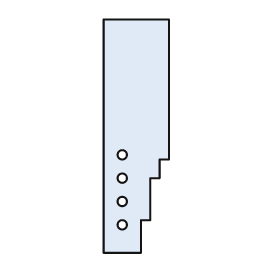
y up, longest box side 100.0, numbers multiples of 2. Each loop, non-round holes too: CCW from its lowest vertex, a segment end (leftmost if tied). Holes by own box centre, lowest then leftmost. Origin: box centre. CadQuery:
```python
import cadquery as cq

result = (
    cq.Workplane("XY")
    .moveTo(-14.0, -50.0)
    .lineTo(2.0, -50.0)
    .lineTo(2.0, -36.0)
    .lineTo(6.0, -36.0)
    .lineTo(6.0, -18.0)
    .lineTo(10.0, -18.0)
    .lineTo(10.0, -10.0)
    .lineTo(14.0, -10.0)
    .lineTo(14.0, 50.0)
    .lineTo(-14.0, 50.0)
    .close()
    .moveTo(-6.0, -38.0)
    .circle(2.0)
    .moveTo(-6.0, -28.0)
    .circle(2.0)
    .moveTo(-6.0, -18.0)
    .circle(2.0)
    .moveTo(-6.0, -8.0)
    .circle(2.0)
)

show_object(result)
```